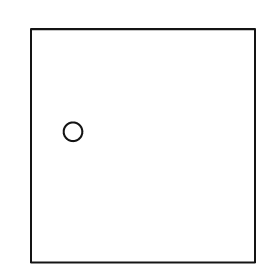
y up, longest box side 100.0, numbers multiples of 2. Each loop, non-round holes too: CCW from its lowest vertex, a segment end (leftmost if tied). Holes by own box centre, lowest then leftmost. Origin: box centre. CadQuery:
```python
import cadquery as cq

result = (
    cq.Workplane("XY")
    .moveTo(-48.0, -50.0)
    .lineTo(48.0, -50.0)
    .lineTo(48.0, 50.0)
    .lineTo(-48.0, 50.0)
    .close()
    .moveTo(-30.0, 6.0)
    .circle(4.0)
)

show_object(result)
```